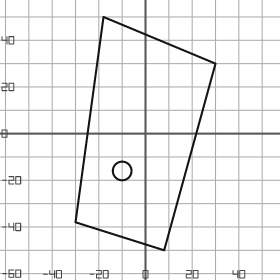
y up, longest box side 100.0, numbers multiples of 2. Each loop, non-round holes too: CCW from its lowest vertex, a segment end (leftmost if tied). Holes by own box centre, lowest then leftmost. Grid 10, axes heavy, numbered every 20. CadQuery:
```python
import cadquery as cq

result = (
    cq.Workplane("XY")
    .moveTo(8.0, -50.0)
    .lineTo(30.0, 30.0)
    .lineTo(-18.0, 50.0)
    .lineTo(-30.0, -38.0)
    .close()
    .moveTo(-10.0, -16.0)
    .circle(4.0)
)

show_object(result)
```